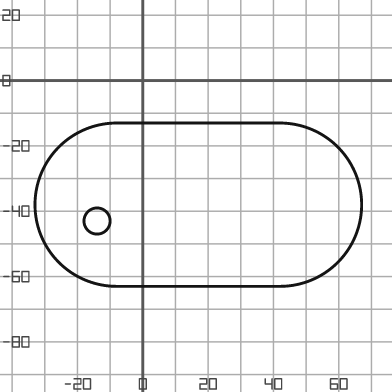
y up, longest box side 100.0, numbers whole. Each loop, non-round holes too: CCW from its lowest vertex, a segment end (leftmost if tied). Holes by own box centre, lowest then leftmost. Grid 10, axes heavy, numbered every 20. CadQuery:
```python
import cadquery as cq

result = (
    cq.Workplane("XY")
    .moveTo(-8.0, -63.0)
    .lineTo(42.0, -63.0)
    .threePointArc((67.0, -38.0), (42.0, -13.0))
    .lineTo(-8.0, -13.0)
    .threePointArc((-33.0, -38.0), (-8.0, -63.0))
    .close()
    .moveTo(-14.0, -43.0)
    .circle(4.0)
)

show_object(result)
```